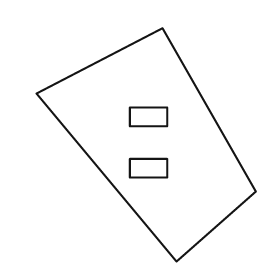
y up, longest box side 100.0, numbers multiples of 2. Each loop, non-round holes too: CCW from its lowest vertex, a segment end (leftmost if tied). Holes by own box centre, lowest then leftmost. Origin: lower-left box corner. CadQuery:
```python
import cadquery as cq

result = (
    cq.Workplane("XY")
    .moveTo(60.0, 0.0)
    .lineTo(94.0, 30.0)
    .lineTo(54.0, 100.0)
    .lineTo(0.0, 72.0)
    .close()
    .moveTo(40.0, 36.0)
    .lineTo(56.0, 36.0)
    .lineTo(56.0, 44.0)
    .lineTo(40.0, 44.0)
    .close()
    .moveTo(40.0, 58.0)
    .lineTo(56.0, 58.0)
    .lineTo(56.0, 66.0)
    .lineTo(40.0, 66.0)
    .close()
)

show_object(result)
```